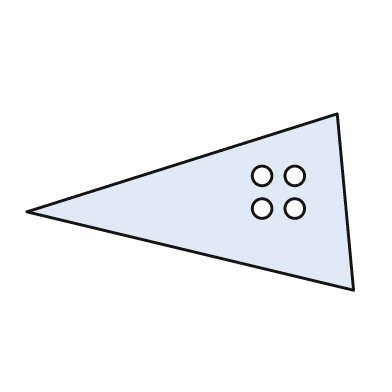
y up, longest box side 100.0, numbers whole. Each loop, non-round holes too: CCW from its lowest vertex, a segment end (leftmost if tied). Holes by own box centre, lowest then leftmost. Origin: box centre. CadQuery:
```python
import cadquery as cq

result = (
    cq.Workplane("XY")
    .moveTo(50.0, -27.0)
    .lineTo(45.0, 27.0)
    .lineTo(-50.0, -3.0)
    .close()
    .moveTo(22.0, -2.0)
    .circle(3.0)
    .moveTo(32.0, -2.0)
    .circle(3.0)
    .moveTo(22.0, 8.0)
    .circle(3.0)
    .moveTo(32.0, 8.0)
    .circle(3.0)
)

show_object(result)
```